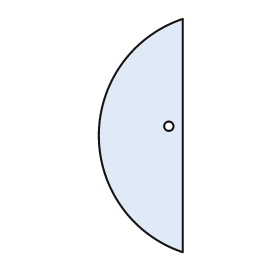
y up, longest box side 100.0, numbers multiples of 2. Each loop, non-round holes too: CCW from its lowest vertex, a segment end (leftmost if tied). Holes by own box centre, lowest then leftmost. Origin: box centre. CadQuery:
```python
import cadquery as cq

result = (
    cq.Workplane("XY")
    .moveTo(18.0, -50.0)
    .lineTo(18.0, 50.0)
    .threePointArc((-18.0, 0.0), (18.0, -50.0))
    .close()
    .moveTo(12.0, 4.0)
    .circle(2.0)
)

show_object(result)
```